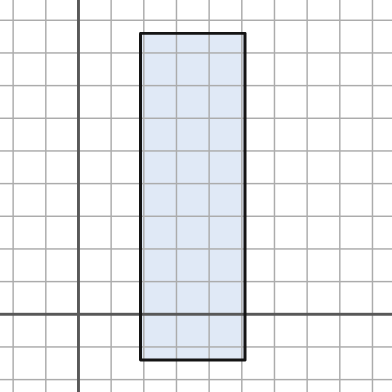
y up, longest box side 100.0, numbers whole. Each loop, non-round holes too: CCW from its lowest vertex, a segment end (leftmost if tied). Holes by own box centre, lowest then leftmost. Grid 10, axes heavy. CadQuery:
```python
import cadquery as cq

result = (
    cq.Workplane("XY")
    .moveTo(19.0, -14.0)
    .lineTo(51.0, -14.0)
    .lineTo(51.0, 86.0)
    .lineTo(19.0, 86.0)
    .close()
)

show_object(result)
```